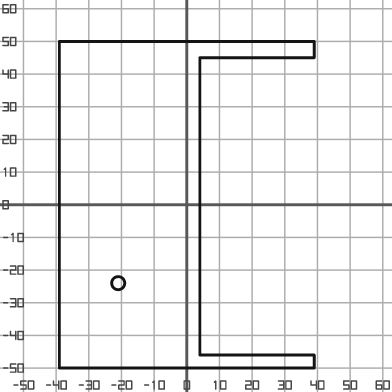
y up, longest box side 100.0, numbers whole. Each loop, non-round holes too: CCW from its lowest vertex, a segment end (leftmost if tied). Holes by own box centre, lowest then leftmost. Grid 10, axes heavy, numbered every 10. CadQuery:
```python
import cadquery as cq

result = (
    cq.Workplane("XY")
    .moveTo(-39.0, -50.0)
    .lineTo(39.0, -50.0)
    .lineTo(39.0, -46.0)
    .lineTo(4.0, -46.0)
    .lineTo(4.0, 45.0)
    .lineTo(39.0, 45.0)
    .lineTo(39.0, 50.0)
    .lineTo(-39.0, 50.0)
    .close()
    .moveTo(-21.0, -24.0)
    .circle(2.0)
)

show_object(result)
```